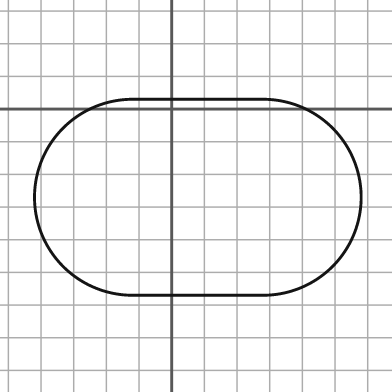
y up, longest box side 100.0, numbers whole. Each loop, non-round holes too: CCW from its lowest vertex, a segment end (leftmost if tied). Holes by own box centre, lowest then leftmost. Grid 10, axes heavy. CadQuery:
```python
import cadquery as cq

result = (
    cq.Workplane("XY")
    .moveTo(-12.0, -57.0)
    .lineTo(28.0, -57.0)
    .threePointArc((58.0, -27.0), (28.0, 3.0))
    .lineTo(-12.0, 3.0)
    .threePointArc((-42.0, -27.0), (-12.0, -57.0))
    .close()
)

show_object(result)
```